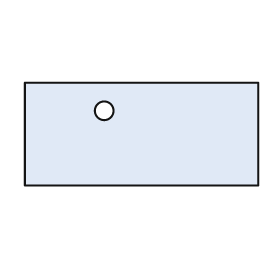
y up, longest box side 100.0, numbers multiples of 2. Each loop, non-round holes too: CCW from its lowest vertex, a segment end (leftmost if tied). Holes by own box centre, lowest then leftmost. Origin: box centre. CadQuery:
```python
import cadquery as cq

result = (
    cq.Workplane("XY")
    .moveTo(-50.0, -22.0)
    .lineTo(50.0, -22.0)
    .lineTo(50.0, 22.0)
    .lineTo(-50.0, 22.0)
    .close()
    .moveTo(-16.0, 10.0)
    .circle(4.0)
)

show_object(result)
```